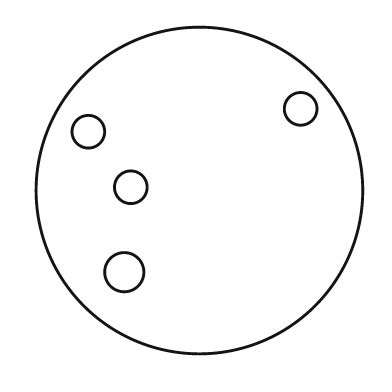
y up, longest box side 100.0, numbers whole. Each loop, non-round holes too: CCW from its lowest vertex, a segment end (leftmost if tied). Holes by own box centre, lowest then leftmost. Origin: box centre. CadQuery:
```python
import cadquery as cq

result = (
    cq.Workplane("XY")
    .moveTo(0.0, 0.0)
    .circle(50.0)
    .moveTo(-23.0, -25.0)
    .circle(6.0)
    .moveTo(-21.0, 1.0)
    .circle(5.0)
    .moveTo(-34.0, 18.0)
    .circle(5.0)
    .moveTo(31.0, 25.0)
    .circle(5.0)
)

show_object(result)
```